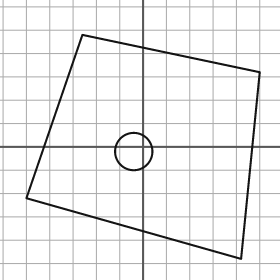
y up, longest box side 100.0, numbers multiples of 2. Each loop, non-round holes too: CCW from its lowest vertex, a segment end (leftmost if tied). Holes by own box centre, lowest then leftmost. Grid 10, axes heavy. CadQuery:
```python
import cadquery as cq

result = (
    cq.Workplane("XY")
    .moveTo(42.0, -48.0)
    .lineTo(50.0, 32.0)
    .lineTo(-26.0, 48.0)
    .lineTo(-50.0, -22.0)
    .close()
    .moveTo(-4.0, -2.0)
    .circle(8.0)
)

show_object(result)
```